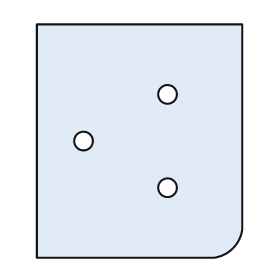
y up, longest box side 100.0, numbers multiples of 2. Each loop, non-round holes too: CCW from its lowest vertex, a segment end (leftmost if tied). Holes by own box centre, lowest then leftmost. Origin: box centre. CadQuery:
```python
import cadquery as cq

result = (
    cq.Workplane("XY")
    .moveTo(-44.0, -50.0)
    .lineTo(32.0, -50.0)
    .threePointArc((40.0, -46.0), (44.0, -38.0))
    .lineTo(44.0, 50.0)
    .lineTo(-44.0, 50.0)
    .close()
    .moveTo(12.0, -20.0)
    .circle(4.0)
    .moveTo(-24.0, 0.0)
    .circle(4.0)
    .moveTo(12.0, 20.0)
    .circle(4.0)
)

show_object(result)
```